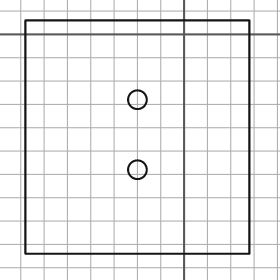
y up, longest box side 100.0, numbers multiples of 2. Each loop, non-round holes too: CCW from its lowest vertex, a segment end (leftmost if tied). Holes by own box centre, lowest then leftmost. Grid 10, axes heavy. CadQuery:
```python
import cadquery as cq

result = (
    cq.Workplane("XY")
    .moveTo(-68.0, -94.0)
    .lineTo(28.0, -94.0)
    .lineTo(28.0, 6.0)
    .lineTo(-68.0, 6.0)
    .close()
    .moveTo(-20.0, -58.0)
    .circle(4.0)
    .moveTo(-20.0, -28.0)
    .circle(4.0)
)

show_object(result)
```